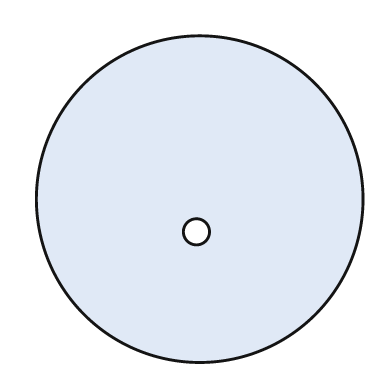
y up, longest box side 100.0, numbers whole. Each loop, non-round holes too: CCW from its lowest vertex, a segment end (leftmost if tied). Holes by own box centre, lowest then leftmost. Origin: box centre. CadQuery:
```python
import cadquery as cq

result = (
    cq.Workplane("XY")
    .moveTo(0.0, 0.0)
    .circle(50.0)
    .moveTo(-1.0, -10.0)
    .circle(4.0)
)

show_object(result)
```